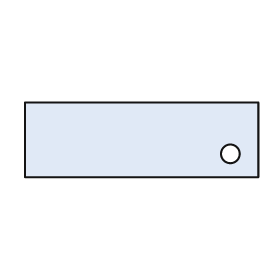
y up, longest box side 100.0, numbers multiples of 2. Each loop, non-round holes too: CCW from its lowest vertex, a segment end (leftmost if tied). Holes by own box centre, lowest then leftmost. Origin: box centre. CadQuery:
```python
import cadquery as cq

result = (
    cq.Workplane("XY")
    .moveTo(-50.0, -16.0)
    .lineTo(50.0, -16.0)
    .lineTo(50.0, 16.0)
    .lineTo(-50.0, 16.0)
    .close()
    .moveTo(38.0, -6.0)
    .circle(4.0)
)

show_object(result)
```